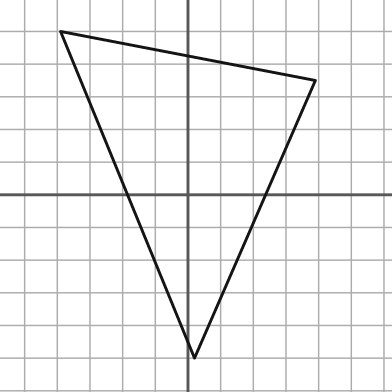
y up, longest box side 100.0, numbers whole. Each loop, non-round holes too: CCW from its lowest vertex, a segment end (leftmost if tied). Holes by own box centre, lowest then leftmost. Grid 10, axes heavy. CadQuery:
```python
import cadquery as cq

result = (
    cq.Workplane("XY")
    .moveTo(2.0, -50.0)
    .lineTo(39.0, 35.0)
    .lineTo(-39.0, 50.0)
    .close()
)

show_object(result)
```